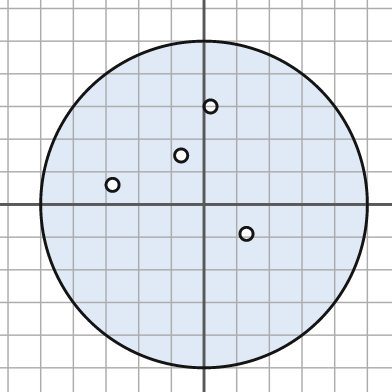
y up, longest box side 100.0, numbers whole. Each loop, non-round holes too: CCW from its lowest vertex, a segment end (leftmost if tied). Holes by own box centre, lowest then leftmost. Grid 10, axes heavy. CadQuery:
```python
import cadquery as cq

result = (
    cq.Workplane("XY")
    .moveTo(0.0, 0.0)
    .circle(50.0)
    .moveTo(13.0, -9.0)
    .circle(2.0)
    .moveTo(-28.0, 6.0)
    .circle(2.0)
    .moveTo(-7.0, 15.0)
    .circle(2.0)
    .moveTo(2.0, 30.0)
    .circle(2.0)
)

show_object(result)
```